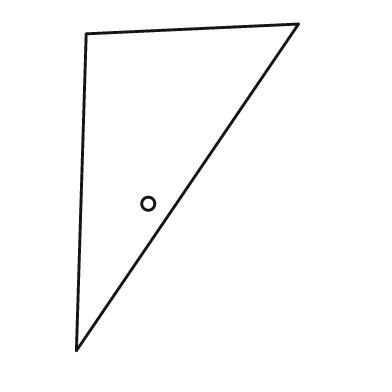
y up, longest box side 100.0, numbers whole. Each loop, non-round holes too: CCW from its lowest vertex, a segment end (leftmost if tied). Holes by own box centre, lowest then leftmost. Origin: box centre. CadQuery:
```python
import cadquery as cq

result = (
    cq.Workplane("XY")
    .moveTo(-34.0, -50.0)
    .lineTo(34.0, 50.0)
    .lineTo(-31.0, 47.0)
    .close()
    .moveTo(-12.0, -5.0)
    .circle(2.0)
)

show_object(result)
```